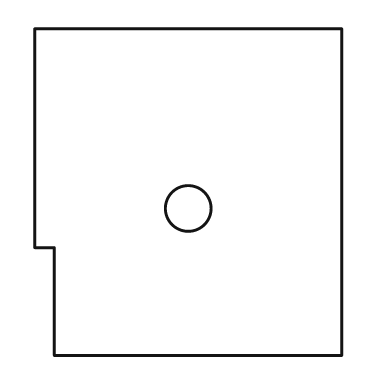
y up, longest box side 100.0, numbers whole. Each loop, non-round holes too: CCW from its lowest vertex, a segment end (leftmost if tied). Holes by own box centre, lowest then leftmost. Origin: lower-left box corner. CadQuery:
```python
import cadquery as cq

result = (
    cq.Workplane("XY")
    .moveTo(6.0, 0.0)
    .lineTo(94.0, 0.0)
    .lineTo(94.0, 100.0)
    .lineTo(0.0, 100.0)
    .lineTo(0.0, 33.0)
    .lineTo(6.0, 33.0)
    .close()
    .moveTo(47.0, 45.0)
    .circle(7.0)
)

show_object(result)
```